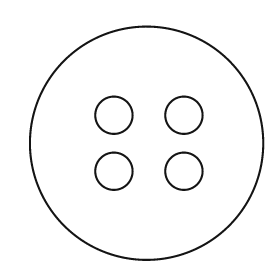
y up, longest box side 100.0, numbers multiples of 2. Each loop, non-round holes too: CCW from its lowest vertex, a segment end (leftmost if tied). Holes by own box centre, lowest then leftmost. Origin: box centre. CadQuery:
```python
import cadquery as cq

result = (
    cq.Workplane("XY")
    .moveTo(0.0, 0.0)
    .circle(50.0)
    .moveTo(-14.0, -12.0)
    .circle(8.0)
    .moveTo(16.0, -12.0)
    .circle(8.0)
    .moveTo(-14.0, 12.0)
    .circle(8.0)
    .moveTo(16.0, 12.0)
    .circle(8.0)
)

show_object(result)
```